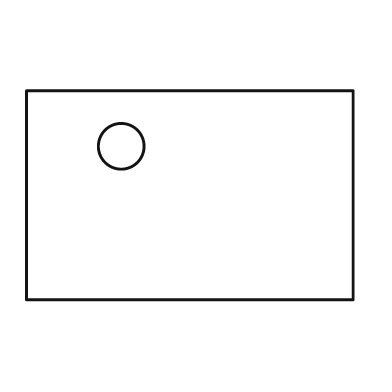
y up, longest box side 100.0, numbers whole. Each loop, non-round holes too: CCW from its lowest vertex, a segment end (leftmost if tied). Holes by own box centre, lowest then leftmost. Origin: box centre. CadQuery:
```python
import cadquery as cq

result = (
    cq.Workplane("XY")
    .moveTo(-50.0, -32.0)
    .lineTo(50.0, -32.0)
    .lineTo(50.0, 32.0)
    .lineTo(-50.0, 32.0)
    .close()
    .moveTo(-21.0, 15.0)
    .circle(7.0)
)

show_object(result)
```